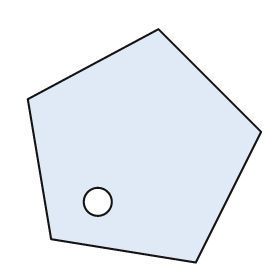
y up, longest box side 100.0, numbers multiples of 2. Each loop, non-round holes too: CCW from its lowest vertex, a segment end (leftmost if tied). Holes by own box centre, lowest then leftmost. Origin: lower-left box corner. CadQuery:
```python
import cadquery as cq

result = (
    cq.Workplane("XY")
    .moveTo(72.0, 0.0)
    .lineTo(100.0, 56.0)
    .lineTo(56.0, 100.0)
    .lineTo(0.0, 70.0)
    .lineTo(10.0, 10.0)
    .close()
    .moveTo(30.0, 26.0)
    .circle(6.0)
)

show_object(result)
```